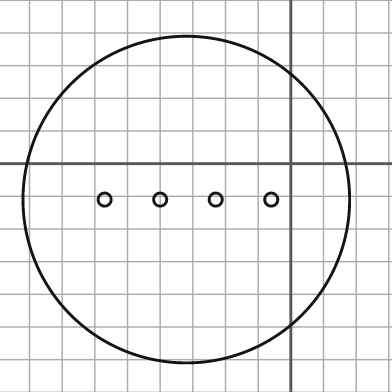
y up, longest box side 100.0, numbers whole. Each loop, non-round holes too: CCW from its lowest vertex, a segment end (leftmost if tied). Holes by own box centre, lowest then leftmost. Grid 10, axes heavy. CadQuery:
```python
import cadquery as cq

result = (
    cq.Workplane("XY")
    .moveTo(-32.0, -11.0)
    .circle(50.0)
    .moveTo(-57.0, -11.0)
    .circle(2.0)
    .moveTo(-40.0, -11.0)
    .circle(2.0)
    .moveTo(-23.0, -11.0)
    .circle(2.0)
    .moveTo(-6.0, -11.0)
    .circle(2.0)
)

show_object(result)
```